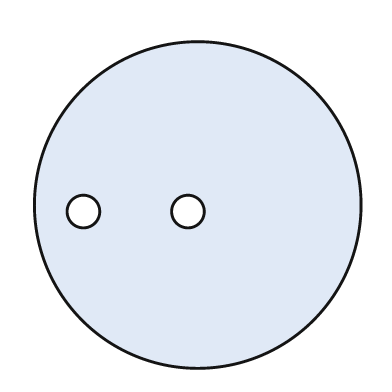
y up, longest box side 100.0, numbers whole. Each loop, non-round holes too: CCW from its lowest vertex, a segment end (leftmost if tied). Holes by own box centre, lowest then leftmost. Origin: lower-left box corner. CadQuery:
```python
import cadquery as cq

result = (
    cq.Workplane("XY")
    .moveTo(50.0, 50.0)
    .circle(50.0)
    .moveTo(15.0, 48.0)
    .circle(5.0)
    .moveTo(47.0, 48.0)
    .circle(5.0)
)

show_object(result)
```